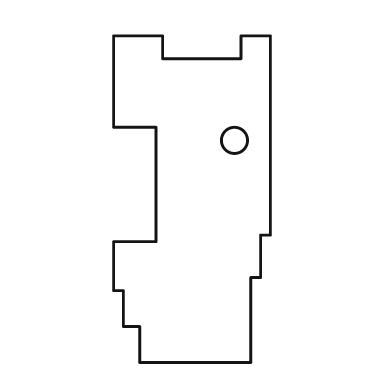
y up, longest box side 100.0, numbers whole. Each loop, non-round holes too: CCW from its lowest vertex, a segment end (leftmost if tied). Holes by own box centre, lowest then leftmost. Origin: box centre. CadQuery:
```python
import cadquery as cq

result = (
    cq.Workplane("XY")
    .moveTo(-16.0, -50.0)
    .lineTo(18.0, -50.0)
    .lineTo(18.0, -24.0)
    .lineTo(21.0, -24.0)
    .lineTo(21.0, -11.0)
    .lineTo(24.0, -11.0)
    .lineTo(24.0, 50.0)
    .lineTo(15.0, 50.0)
    .lineTo(15.0, 43.0)
    .lineTo(-9.0, 43.0)
    .lineTo(-9.0, 50.0)
    .lineTo(-24.0, 50.0)
    .lineTo(-24.0, 22.0)
    .lineTo(-11.0, 22.0)
    .lineTo(-11.0, -13.0)
    .lineTo(-24.0, -13.0)
    .lineTo(-24.0, -28.0)
    .lineTo(-21.0, -28.0)
    .lineTo(-21.0, -39.0)
    .lineTo(-16.0, -39.0)
    .close()
    .moveTo(13.0, 18.0)
    .circle(4.0)
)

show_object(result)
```